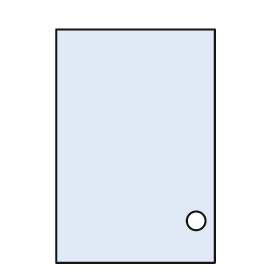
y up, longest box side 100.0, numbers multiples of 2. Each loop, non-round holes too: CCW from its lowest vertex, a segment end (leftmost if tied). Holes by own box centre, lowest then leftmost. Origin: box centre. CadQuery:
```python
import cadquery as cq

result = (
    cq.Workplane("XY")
    .moveTo(-34.0, -50.0)
    .lineTo(34.0, -50.0)
    .lineTo(34.0, 50.0)
    .lineTo(-34.0, 50.0)
    .close()
    .moveTo(26.0, -32.0)
    .circle(4.0)
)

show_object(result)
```